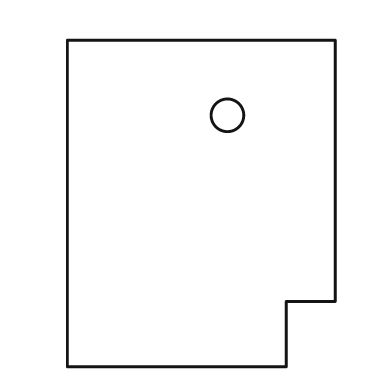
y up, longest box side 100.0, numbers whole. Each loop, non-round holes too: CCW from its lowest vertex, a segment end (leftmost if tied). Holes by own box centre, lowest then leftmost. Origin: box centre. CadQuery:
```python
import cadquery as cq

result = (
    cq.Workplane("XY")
    .moveTo(-41.0, -50.0)
    .lineTo(26.0, -50.0)
    .lineTo(26.0, -30.0)
    .lineTo(41.0, -30.0)
    .lineTo(41.0, 50.0)
    .lineTo(-41.0, 50.0)
    .close()
    .moveTo(8.0, 27.0)
    .circle(5.0)
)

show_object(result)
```